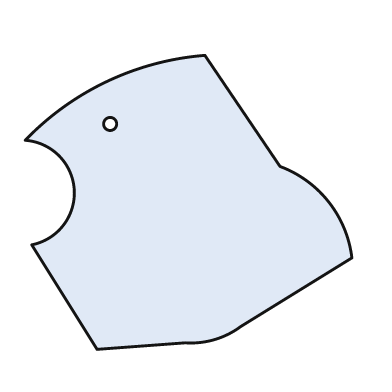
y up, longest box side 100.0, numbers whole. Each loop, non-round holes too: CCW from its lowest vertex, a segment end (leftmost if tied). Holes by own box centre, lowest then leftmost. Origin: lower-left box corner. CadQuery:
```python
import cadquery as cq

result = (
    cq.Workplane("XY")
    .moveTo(22.0, 0.0)
    .lineTo(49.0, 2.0)
    .threePointArc((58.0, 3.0), (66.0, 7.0))
    .lineTo(100.0, 28.0)
    .threePointArc((93.0, 45.0), (78.0, 56.0))
    .lineTo(55.0, 90.0)
    .threePointArc((25.0, 82.0), (0.0, 64.0))
    .threePointArc((15.0, 49.0), (2.0, 32.0))
    .close()
    .moveTo(26.0, 69.0)
    .circle(2.0)
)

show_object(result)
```